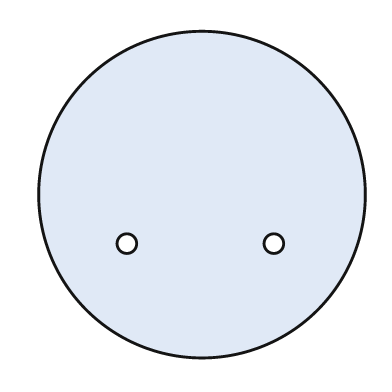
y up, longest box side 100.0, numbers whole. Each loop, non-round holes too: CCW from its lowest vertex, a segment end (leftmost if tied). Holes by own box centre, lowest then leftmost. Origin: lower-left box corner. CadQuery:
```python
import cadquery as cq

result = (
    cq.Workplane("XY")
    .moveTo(50.0, 50.0)
    .circle(50.0)
    .moveTo(27.0, 35.0)
    .circle(3.0)
    .moveTo(72.0, 35.0)
    .circle(3.0)
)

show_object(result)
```